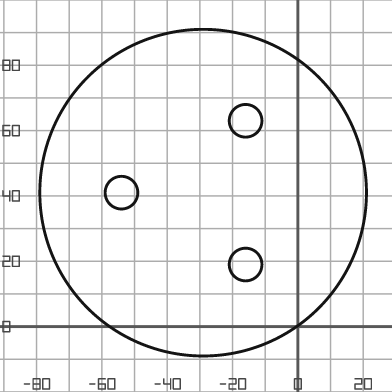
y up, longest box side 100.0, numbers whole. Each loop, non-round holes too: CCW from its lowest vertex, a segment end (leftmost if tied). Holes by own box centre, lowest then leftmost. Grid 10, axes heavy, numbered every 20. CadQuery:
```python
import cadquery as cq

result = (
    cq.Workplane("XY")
    .moveTo(-29.0, 41.0)
    .circle(50.0)
    .moveTo(-16.0, 19.0)
    .circle(5.0)
    .moveTo(-54.0, 41.0)
    .circle(5.0)
    .moveTo(-16.0, 63.0)
    .circle(5.0)
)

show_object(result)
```